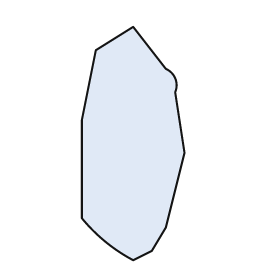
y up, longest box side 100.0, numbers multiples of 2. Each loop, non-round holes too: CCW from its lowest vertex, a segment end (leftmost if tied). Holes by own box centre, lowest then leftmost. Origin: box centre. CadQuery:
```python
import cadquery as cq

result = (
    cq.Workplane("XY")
    .moveTo(0.0, -50.0)
    .lineTo(8.0, -46.0)
    .lineTo(14.0, -36.0)
    .lineTo(22.0, -4.0)
    .lineTo(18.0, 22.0)
    .threePointArc((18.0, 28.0), (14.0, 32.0))
    .lineTo(0.0, 50.0)
    .lineTo(-16.0, 40.0)
    .lineTo(-22.0, 10.0)
    .lineTo(-22.0, -32.0)
    .threePointArc((-12.0, -42.0), (0.0, -50.0))
    .close()
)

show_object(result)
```